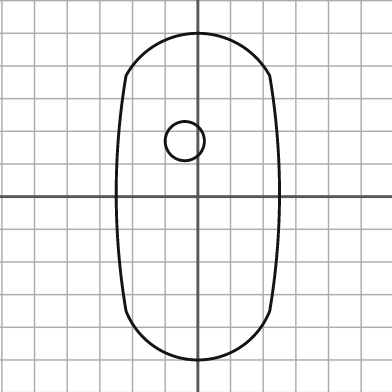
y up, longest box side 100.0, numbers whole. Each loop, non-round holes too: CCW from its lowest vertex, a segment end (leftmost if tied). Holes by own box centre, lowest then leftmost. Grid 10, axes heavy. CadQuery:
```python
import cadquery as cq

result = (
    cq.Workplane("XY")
    .moveTo(-22.0, -35.0)
    .threePointArc((0.0, -50.0), (22.0, -35.0))
    .threePointArc((25.0, 1.0), (22.0, 37.0))
    .threePointArc((0.0, 50.0), (-22.0, 37.0))
    .threePointArc((-25.0, 1.0), (-22.0, -35.0))
    .close()
    .moveTo(-4.0, 17.0)
    .circle(6.0)
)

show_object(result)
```